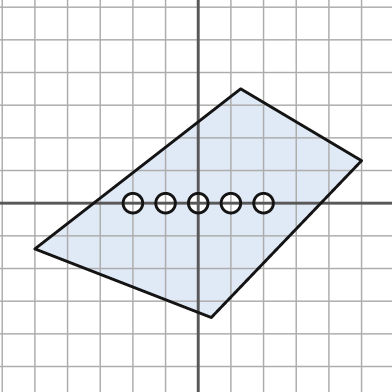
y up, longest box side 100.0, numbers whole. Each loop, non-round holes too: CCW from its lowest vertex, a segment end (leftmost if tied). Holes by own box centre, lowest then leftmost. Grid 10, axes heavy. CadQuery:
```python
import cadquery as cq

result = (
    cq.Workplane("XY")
    .moveTo(4.0, -35.0)
    .lineTo(50.0, 13.0)
    .lineTo(13.0, 35.0)
    .lineTo(-50.0, -14.0)
    .close()
    .moveTo(-20.0, 0.0)
    .circle(3.0)
    .moveTo(-10.0, 0.0)
    .circle(3.0)
    .moveTo(0.0, 0.0)
    .circle(3.0)
    .moveTo(10.0, 0.0)
    .circle(3.0)
    .moveTo(20.0, 0.0)
    .circle(3.0)
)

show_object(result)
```